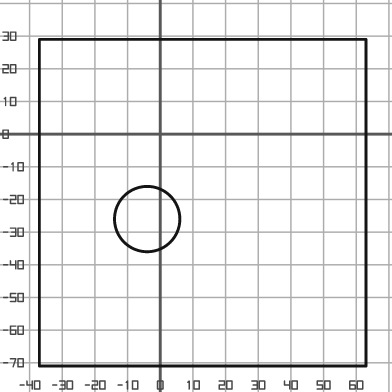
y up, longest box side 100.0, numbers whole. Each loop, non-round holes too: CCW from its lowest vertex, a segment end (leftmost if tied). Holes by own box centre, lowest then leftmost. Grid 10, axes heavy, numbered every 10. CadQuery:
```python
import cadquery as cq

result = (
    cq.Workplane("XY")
    .moveTo(-37.0, -71.0)
    .lineTo(63.0, -71.0)
    .lineTo(63.0, 29.0)
    .lineTo(-37.0, 29.0)
    .close()
    .moveTo(-4.0, -26.0)
    .circle(10.0)
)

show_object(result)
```